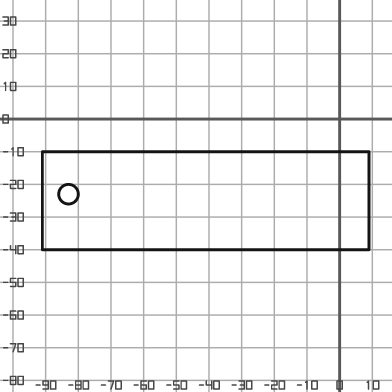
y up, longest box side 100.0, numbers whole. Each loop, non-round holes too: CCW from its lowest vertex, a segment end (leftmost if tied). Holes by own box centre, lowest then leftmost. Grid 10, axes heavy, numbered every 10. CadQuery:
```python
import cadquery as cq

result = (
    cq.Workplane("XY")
    .moveTo(-91.0, -40.0)
    .lineTo(9.0, -40.0)
    .lineTo(9.0, -10.0)
    .lineTo(-91.0, -10.0)
    .close()
    .moveTo(-83.0, -23.0)
    .circle(3.0)
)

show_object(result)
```